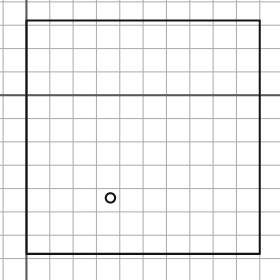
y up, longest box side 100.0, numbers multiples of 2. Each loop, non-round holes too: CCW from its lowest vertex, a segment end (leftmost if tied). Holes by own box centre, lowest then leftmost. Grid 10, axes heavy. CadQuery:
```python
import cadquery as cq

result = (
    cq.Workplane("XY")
    .moveTo(0.0, -68.0)
    .lineTo(100.0, -68.0)
    .lineTo(100.0, 32.0)
    .lineTo(0.0, 32.0)
    .close()
    .moveTo(36.0, -44.0)
    .circle(2.0)
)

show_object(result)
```